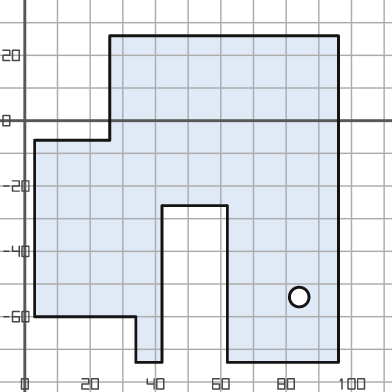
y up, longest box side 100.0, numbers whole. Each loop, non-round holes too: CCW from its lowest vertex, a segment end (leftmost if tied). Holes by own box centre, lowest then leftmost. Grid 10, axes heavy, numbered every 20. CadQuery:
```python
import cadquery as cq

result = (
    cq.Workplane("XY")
    .moveTo(34.0, -74.0)
    .lineTo(42.0, -74.0)
    .lineTo(42.0, -26.0)
    .lineTo(62.0, -26.0)
    .lineTo(62.0, -74.0)
    .lineTo(96.0, -74.0)
    .lineTo(96.0, 26.0)
    .lineTo(26.0, 26.0)
    .lineTo(26.0, -6.0)
    .lineTo(3.0, -6.0)
    .lineTo(3.0, -60.0)
    .lineTo(34.0, -60.0)
    .close()
    .moveTo(84.0, -54.0)
    .circle(3.0)
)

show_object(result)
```